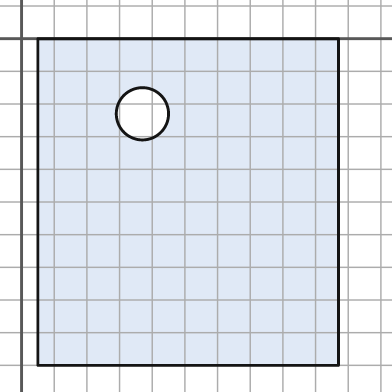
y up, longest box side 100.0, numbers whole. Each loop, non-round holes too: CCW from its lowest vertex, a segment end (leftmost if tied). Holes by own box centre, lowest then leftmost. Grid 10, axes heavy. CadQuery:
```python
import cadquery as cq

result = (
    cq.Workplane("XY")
    .moveTo(5.0, -100.0)
    .lineTo(97.0, -100.0)
    .lineTo(97.0, 0.0)
    .lineTo(5.0, 0.0)
    .close()
    .moveTo(37.0, -23.0)
    .circle(8.0)
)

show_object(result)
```